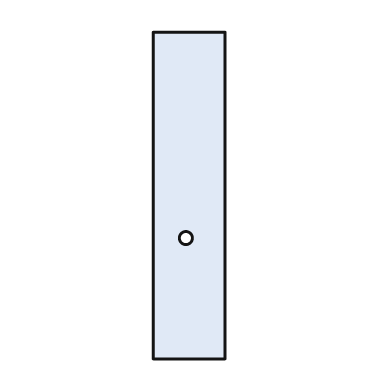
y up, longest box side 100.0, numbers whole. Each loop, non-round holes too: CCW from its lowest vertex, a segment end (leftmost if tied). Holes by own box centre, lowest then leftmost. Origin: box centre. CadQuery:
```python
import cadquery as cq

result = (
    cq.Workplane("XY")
    .moveTo(-11.0, -50.0)
    .lineTo(11.0, -50.0)
    .lineTo(11.0, 50.0)
    .lineTo(-11.0, 50.0)
    .close()
    .moveTo(-1.0, -13.0)
    .circle(2.0)
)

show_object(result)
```